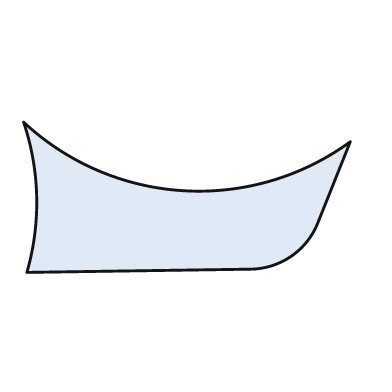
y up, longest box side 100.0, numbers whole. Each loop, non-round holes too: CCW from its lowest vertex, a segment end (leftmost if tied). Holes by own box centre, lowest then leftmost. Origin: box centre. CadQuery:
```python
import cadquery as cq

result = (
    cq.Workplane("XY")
    .moveTo(-49.0, -23.0)
    .lineTo(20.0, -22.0)
    .threePointArc((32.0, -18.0), (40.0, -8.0))
    .lineTo(50.0, 17.0)
    .threePointArc((-1.0, 2.0), (-50.0, 23.0))
    .threePointArc((-46.0, 0.0), (-49.0, -23.0))
    .close()
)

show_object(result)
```